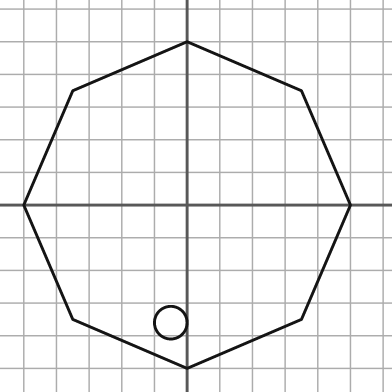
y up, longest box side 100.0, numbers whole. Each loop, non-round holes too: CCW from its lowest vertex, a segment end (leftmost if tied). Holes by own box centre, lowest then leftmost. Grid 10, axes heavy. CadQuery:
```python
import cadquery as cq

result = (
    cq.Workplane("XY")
    .moveTo(0.0, -50.0)
    .lineTo(35.0, -35.0)
    .lineTo(50.0, 0.0)
    .lineTo(35.0, 35.0)
    .lineTo(0.0, 50.0)
    .lineTo(-35.0, 35.0)
    .lineTo(-50.0, 0.0)
    .lineTo(-35.0, -35.0)
    .close()
    .moveTo(-5.0, -36.0)
    .circle(5.0)
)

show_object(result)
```